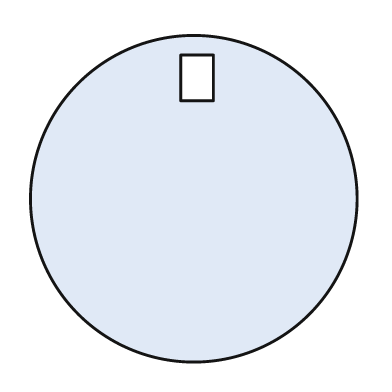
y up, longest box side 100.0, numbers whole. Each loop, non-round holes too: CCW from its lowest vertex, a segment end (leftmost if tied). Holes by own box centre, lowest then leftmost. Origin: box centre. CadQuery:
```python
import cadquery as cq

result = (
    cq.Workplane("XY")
    .moveTo(0.0, 0.0)
    .circle(50.0)
    .moveTo(-4.0, 30.0)
    .lineTo(6.0, 30.0)
    .lineTo(6.0, 44.0)
    .lineTo(-4.0, 44.0)
    .close()
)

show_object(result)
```